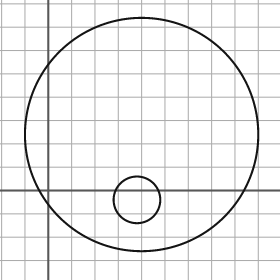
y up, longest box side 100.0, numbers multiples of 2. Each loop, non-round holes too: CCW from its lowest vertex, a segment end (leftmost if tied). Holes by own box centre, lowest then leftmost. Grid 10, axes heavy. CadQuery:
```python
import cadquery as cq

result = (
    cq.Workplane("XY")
    .moveTo(40.0, 24.0)
    .circle(50.0)
    .moveTo(38.0, -4.0)
    .circle(10.0)
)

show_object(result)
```